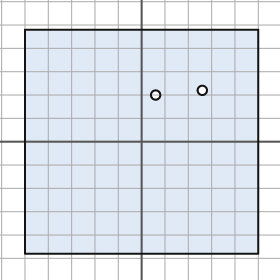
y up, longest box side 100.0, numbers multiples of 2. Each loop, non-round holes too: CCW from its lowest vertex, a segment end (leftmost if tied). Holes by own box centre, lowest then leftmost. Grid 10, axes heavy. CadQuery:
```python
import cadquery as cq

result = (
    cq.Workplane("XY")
    .moveTo(-50.0, -48.0)
    .lineTo(50.0, -48.0)
    .lineTo(50.0, 48.0)
    .lineTo(-50.0, 48.0)
    .close()
    .moveTo(6.0, 20.0)
    .circle(2.0)
    .moveTo(26.0, 22.0)
    .circle(2.0)
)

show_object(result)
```